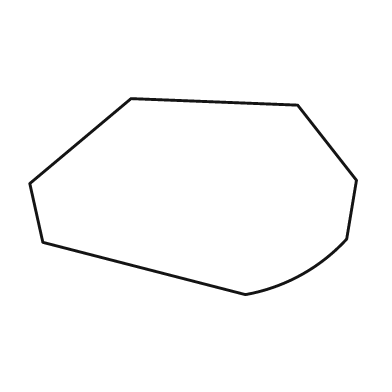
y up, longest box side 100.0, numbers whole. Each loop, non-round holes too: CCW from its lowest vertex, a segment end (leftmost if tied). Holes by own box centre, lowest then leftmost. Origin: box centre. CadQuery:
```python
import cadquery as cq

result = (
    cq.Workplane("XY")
    .moveTo(16.0, -30.0)
    .threePointArc((33.0, -24.0), (47.0, -13.0))
    .lineTo(50.0, 5.0)
    .lineTo(32.0, 28.0)
    .lineTo(-19.0, 30.0)
    .lineTo(-50.0, 4.0)
    .lineTo(-46.0, -14.0)
    .close()
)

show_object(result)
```